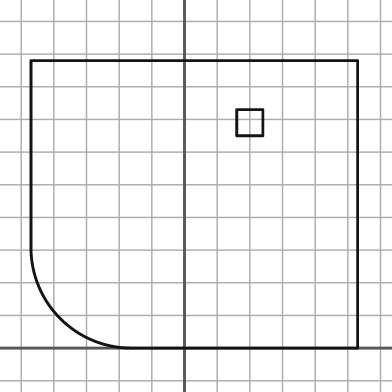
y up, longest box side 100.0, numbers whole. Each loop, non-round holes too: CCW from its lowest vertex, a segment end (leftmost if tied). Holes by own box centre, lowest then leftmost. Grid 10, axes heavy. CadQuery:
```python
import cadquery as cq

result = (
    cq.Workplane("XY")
    .moveTo(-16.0, 0.0)
    .lineTo(53.0, 0.0)
    .lineTo(53.0, 88.0)
    .lineTo(-47.0, 88.0)
    .lineTo(-47.0, 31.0)
    .threePointArc((-38.0, 9.0), (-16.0, 0.0))
    .close()
    .moveTo(16.0, 65.0)
    .lineTo(24.0, 65.0)
    .lineTo(24.0, 73.0)
    .lineTo(16.0, 73.0)
    .close()
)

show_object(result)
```